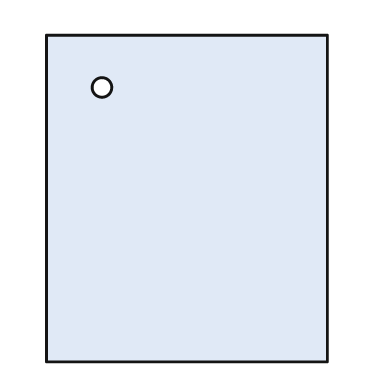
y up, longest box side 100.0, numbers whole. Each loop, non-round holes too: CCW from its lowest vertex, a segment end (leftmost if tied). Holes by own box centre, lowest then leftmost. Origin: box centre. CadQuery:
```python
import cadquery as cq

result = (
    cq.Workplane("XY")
    .moveTo(-43.0, -50.0)
    .lineTo(43.0, -50.0)
    .lineTo(43.0, 50.0)
    .lineTo(-43.0, 50.0)
    .close()
    .moveTo(-26.0, 34.0)
    .circle(3.0)
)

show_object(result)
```